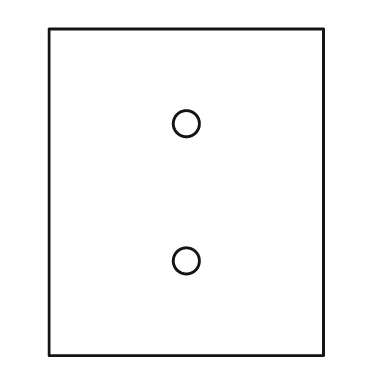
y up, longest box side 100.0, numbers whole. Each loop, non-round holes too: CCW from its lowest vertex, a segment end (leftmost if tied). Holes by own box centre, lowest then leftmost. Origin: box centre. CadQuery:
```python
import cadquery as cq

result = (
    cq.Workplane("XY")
    .moveTo(-42.0, -50.0)
    .lineTo(42.0, -50.0)
    .lineTo(42.0, 50.0)
    .lineTo(-42.0, 50.0)
    .close()
    .moveTo(0.0, -21.0)
    .circle(4.0)
    .moveTo(0.0, 21.0)
    .circle(4.0)
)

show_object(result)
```